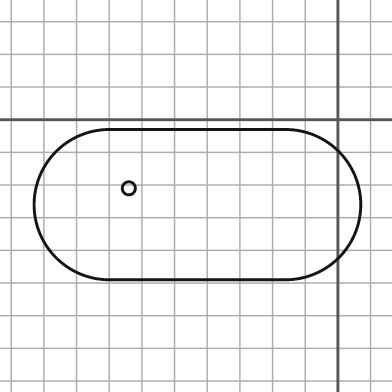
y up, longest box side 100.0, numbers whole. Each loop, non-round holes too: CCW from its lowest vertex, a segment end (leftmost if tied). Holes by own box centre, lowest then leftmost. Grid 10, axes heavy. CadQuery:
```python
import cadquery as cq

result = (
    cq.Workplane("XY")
    .moveTo(-70.0, -49.0)
    .lineTo(-16.0, -49.0)
    .threePointArc((7.0, -26.0), (-16.0, -3.0))
    .lineTo(-70.0, -3.0)
    .threePointArc((-93.0, -26.0), (-70.0, -49.0))
    .close()
    .moveTo(-64.0, -21.0)
    .circle(2.0)
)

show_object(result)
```